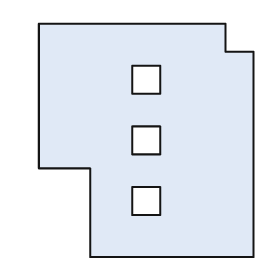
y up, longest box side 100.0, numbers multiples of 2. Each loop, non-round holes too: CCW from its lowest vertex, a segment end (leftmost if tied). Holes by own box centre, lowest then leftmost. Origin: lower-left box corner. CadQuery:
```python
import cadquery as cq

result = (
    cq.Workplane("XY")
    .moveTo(22.0, 0.0)
    .lineTo(92.0, 0.0)
    .lineTo(92.0, 88.0)
    .lineTo(80.0, 88.0)
    .lineTo(80.0, 100.0)
    .lineTo(0.0, 100.0)
    .lineTo(0.0, 38.0)
    .lineTo(22.0, 38.0)
    .close()
    .moveTo(40.0, 18.0)
    .lineTo(52.0, 18.0)
    .lineTo(52.0, 30.0)
    .lineTo(40.0, 30.0)
    .close()
    .moveTo(40.0, 44.0)
    .lineTo(52.0, 44.0)
    .lineTo(52.0, 56.0)
    .lineTo(40.0, 56.0)
    .close()
    .moveTo(40.0, 70.0)
    .lineTo(52.0, 70.0)
    .lineTo(52.0, 82.0)
    .lineTo(40.0, 82.0)
    .close()
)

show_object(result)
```